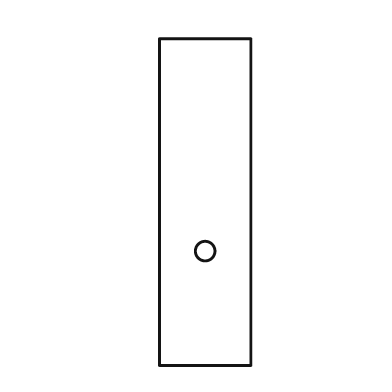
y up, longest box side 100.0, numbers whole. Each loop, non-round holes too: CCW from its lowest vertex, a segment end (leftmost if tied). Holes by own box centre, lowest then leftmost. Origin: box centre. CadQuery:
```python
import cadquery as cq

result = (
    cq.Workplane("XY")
    .moveTo(-14.0, -50.0)
    .lineTo(14.0, -50.0)
    .lineTo(14.0, 50.0)
    .lineTo(-14.0, 50.0)
    .close()
    .moveTo(0.0, -15.0)
    .circle(3.0)
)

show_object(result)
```